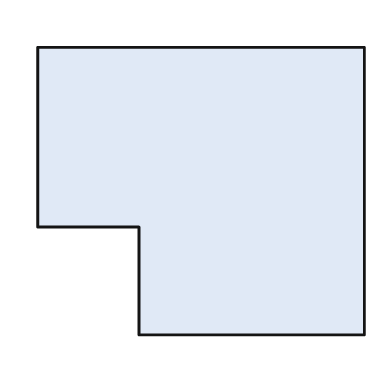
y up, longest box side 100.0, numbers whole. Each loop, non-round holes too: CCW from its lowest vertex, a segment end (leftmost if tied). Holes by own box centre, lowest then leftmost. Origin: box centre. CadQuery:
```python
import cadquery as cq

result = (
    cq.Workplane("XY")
    .moveTo(-19.0, -44.0)
    .lineTo(50.0, -44.0)
    .lineTo(50.0, 44.0)
    .lineTo(-50.0, 44.0)
    .lineTo(-50.0, -11.0)
    .lineTo(-19.0, -11.0)
    .close()
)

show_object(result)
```